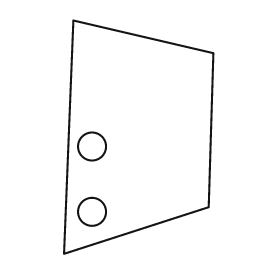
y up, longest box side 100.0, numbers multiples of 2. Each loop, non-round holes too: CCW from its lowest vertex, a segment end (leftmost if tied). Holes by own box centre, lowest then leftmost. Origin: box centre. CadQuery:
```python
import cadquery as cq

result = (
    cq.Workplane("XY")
    .moveTo(-32.0, -50.0)
    .lineTo(30.0, -30.0)
    .lineTo(32.0, 36.0)
    .lineTo(-28.0, 50.0)
    .close()
    .moveTo(-20.0, -32.0)
    .circle(6.0)
    .moveTo(-20.0, -4.0)
    .circle(6.0)
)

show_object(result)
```